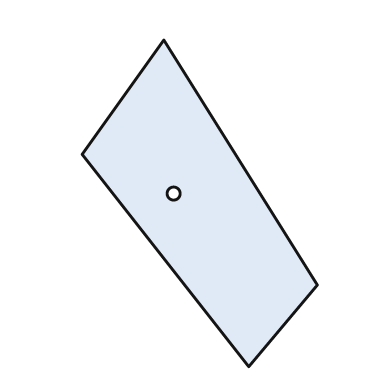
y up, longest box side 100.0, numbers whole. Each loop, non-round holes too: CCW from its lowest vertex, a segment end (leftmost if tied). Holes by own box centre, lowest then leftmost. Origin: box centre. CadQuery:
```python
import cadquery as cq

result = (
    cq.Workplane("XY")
    .moveTo(15.0, -50.0)
    .lineTo(36.0, -25.0)
    .lineTo(-11.0, 50.0)
    .lineTo(-36.0, 15.0)
    .close()
    .moveTo(-8.0, 3.0)
    .circle(2.0)
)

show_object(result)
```